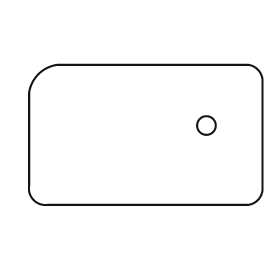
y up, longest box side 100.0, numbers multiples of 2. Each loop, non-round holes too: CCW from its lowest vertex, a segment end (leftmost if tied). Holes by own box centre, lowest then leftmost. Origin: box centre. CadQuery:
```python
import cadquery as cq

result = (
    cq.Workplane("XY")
    .moveTo(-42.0, -30.0)
    .lineTo(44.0, -30.0)
    .threePointArc((48.0, -28.0), (50.0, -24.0))
    .lineTo(50.0, 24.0)
    .threePointArc((48.0, 28.0), (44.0, 30.0))
    .lineTo(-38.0, 30.0)
    .threePointArc((-46.0, 26.0), (-50.0, 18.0))
    .lineTo(-50.0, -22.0)
    .threePointArc((-48.0, -28.0), (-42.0, -30.0))
    .close()
    .moveTo(26.0, 4.0)
    .circle(4.0)
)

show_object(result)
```